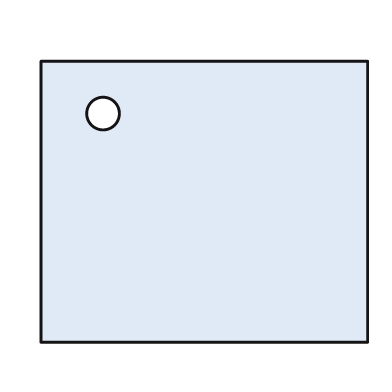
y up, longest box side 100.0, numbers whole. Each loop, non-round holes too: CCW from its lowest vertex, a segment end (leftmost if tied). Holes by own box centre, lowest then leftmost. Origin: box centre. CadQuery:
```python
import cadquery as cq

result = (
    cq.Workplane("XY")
    .moveTo(-50.0, -43.0)
    .lineTo(50.0, -43.0)
    .lineTo(50.0, 43.0)
    .lineTo(-50.0, 43.0)
    .close()
    .moveTo(-31.0, 27.0)
    .circle(5.0)
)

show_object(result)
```